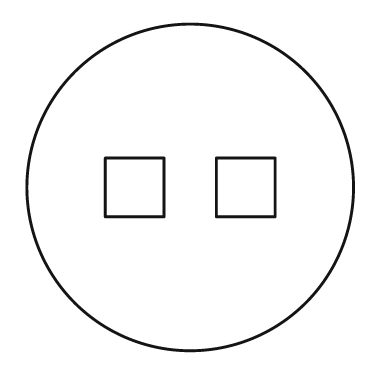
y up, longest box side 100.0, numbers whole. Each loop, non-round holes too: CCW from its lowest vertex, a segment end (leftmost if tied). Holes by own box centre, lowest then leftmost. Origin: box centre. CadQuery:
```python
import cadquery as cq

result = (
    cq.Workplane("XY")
    .moveTo(0.0, 0.0)
    .circle(50.0)
    .moveTo(-26.0, -9.0)
    .lineTo(-8.0, -9.0)
    .lineTo(-8.0, 9.0)
    .lineTo(-26.0, 9.0)
    .close()
    .moveTo(8.0, -9.0)
    .lineTo(26.0, -9.0)
    .lineTo(26.0, 9.0)
    .lineTo(8.0, 9.0)
    .close()
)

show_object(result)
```